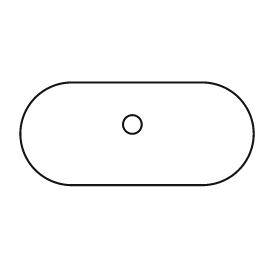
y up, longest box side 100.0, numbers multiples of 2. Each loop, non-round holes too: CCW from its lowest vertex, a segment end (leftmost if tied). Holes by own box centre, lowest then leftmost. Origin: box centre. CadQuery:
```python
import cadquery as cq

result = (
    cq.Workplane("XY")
    .moveTo(-28.0, -22.0)
    .lineTo(28.0, -22.0)
    .threePointArc((50.0, 0.0), (28.0, 22.0))
    .lineTo(-28.0, 22.0)
    .threePointArc((-50.0, 0.0), (-28.0, -22.0))
    .close()
    .moveTo(-2.0, 4.0)
    .circle(4.0)
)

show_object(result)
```